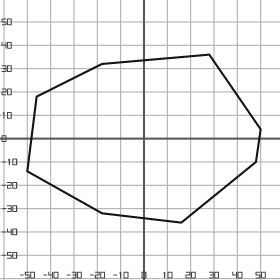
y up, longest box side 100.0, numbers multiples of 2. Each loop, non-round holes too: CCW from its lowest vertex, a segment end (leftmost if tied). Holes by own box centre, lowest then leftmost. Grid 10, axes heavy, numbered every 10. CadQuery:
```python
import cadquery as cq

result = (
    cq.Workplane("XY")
    .moveTo(16.0, -36.0)
    .lineTo(48.0, -10.0)
    .lineTo(50.0, 4.0)
    .lineTo(28.0, 36.0)
    .lineTo(-18.0, 32.0)
    .lineTo(-46.0, 18.0)
    .lineTo(-50.0, -14.0)
    .lineTo(-18.0, -32.0)
    .close()
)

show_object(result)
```